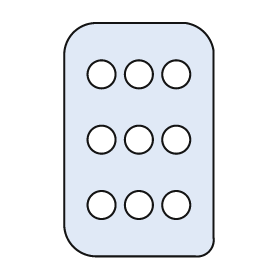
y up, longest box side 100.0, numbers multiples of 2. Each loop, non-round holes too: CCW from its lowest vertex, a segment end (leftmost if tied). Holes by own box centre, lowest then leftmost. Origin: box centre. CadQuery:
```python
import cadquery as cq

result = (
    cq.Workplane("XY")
    .moveTo(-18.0, -50.0)
    .lineTo(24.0, -50.0)
    .threePointArc((30.0, -48.0), (32.0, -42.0))
    .lineTo(32.0, 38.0)
    .threePointArc((28.0, 46.0), (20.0, 50.0))
    .lineTo(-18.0, 50.0)
    .threePointArc((-28.0, 46.0), (-32.0, 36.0))
    .lineTo(-32.0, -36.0)
    .threePointArc((-28.0, -46.0), (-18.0, -50.0))
    .close()
    .moveTo(-16.0, -28.0)
    .circle(6.0)
    .moveTo(0.0, -28.0)
    .circle(6.0)
    .moveTo(16.0, -28.0)
    .circle(6.0)
    .moveTo(-16.0, 0.0)
    .circle(6.0)
    .moveTo(0.0, 0.0)
    .circle(6.0)
    .moveTo(16.0, 0.0)
    .circle(6.0)
    .moveTo(-16.0, 28.0)
    .circle(6.0)
    .moveTo(0.0, 28.0)
    .circle(6.0)
    .moveTo(16.0, 28.0)
    .circle(6.0)
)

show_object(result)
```